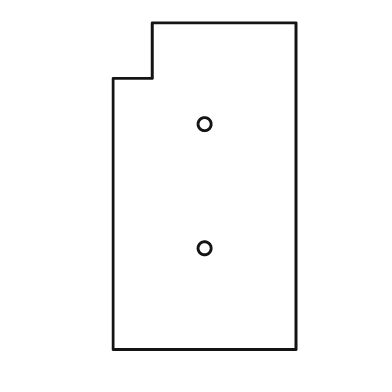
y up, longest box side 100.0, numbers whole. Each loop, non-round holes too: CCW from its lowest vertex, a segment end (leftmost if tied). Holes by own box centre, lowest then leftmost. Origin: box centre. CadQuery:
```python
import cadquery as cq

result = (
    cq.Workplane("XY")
    .moveTo(-28.0, -50.0)
    .lineTo(28.0, -50.0)
    .lineTo(28.0, 50.0)
    .lineTo(-16.0, 50.0)
    .lineTo(-16.0, 33.0)
    .lineTo(-28.0, 33.0)
    .close()
    .moveTo(0.0, -19.0)
    .circle(2.0)
    .moveTo(0.0, 19.0)
    .circle(2.0)
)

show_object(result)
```